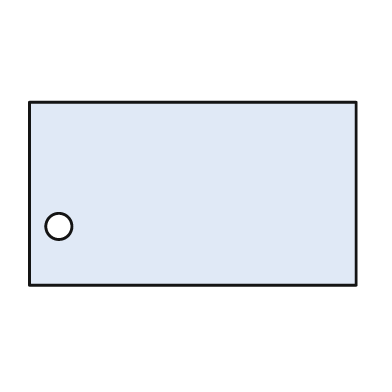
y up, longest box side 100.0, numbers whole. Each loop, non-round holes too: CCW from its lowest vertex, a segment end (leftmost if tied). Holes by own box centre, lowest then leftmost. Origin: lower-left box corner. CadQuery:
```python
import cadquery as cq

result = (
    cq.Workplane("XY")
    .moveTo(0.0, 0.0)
    .lineTo(100.0, 0.0)
    .lineTo(100.0, 56.0)
    .lineTo(0.0, 56.0)
    .close()
    .moveTo(9.0, 18.0)
    .circle(4.0)
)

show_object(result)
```